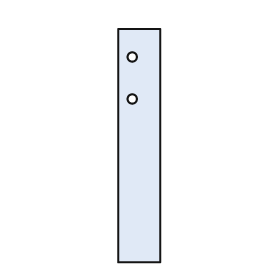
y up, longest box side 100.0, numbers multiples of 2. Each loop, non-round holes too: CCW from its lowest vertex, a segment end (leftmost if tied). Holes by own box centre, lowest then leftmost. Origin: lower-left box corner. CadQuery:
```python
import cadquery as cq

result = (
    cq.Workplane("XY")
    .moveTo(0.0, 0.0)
    .lineTo(18.0, 0.0)
    .lineTo(18.0, 100.0)
    .lineTo(0.0, 100.0)
    .close()
    .moveTo(6.0, 70.0)
    .circle(2.0)
    .moveTo(6.0, 88.0)
    .circle(2.0)
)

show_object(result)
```